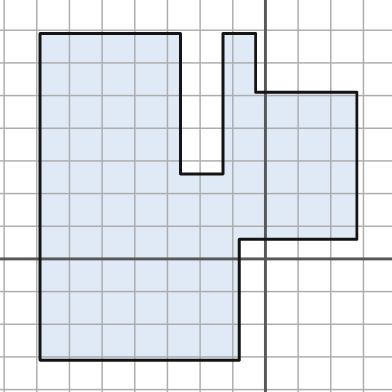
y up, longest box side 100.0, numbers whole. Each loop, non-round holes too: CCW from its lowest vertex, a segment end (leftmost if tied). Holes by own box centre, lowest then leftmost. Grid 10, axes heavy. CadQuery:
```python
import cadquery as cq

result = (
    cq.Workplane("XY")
    .moveTo(-69.0, -31.0)
    .lineTo(-8.0, -31.0)
    .lineTo(-8.0, 6.0)
    .lineTo(28.0, 6.0)
    .lineTo(28.0, 51.0)
    .lineTo(-3.0, 51.0)
    .lineTo(-3.0, 69.0)
    .lineTo(-13.0, 69.0)
    .lineTo(-13.0, 26.0)
    .lineTo(-26.0, 26.0)
    .lineTo(-26.0, 69.0)
    .lineTo(-69.0, 69.0)
    .close()
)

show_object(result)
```